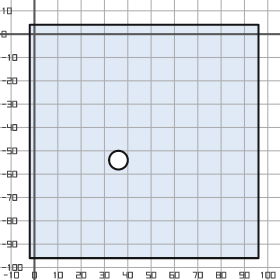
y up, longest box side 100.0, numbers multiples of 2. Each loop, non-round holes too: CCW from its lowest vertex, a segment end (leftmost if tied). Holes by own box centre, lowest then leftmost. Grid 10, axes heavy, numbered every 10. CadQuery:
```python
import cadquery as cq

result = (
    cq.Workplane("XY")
    .moveTo(-2.0, -96.0)
    .lineTo(96.0, -96.0)
    .lineTo(96.0, 4.0)
    .lineTo(-2.0, 4.0)
    .close()
    .moveTo(36.0, -54.0)
    .circle(4.0)
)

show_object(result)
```